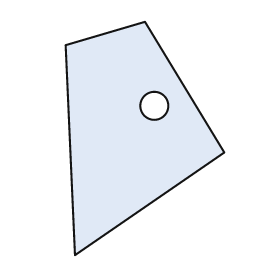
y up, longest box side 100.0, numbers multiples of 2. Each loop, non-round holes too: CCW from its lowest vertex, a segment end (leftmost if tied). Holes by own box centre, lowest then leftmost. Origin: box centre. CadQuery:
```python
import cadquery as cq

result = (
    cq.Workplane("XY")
    .moveTo(-30.0, -50.0)
    .lineTo(34.0, -6.0)
    .lineTo(0.0, 50.0)
    .lineTo(-34.0, 40.0)
    .close()
    .moveTo(4.0, 14.0)
    .circle(6.0)
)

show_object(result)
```